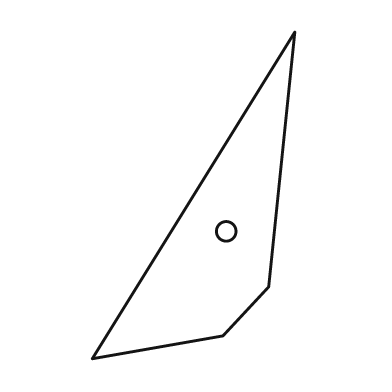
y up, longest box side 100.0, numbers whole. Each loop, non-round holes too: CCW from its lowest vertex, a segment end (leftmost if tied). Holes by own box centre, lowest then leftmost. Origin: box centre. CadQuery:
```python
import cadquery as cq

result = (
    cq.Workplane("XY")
    .moveTo(-31.0, -50.0)
    .lineTo(9.0, -43.0)
    .lineTo(23.0, -28.0)
    .lineTo(31.0, 50.0)
    .close()
    .moveTo(10.0, -11.0)
    .circle(3.0)
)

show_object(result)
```